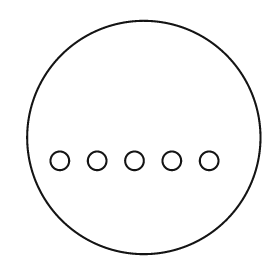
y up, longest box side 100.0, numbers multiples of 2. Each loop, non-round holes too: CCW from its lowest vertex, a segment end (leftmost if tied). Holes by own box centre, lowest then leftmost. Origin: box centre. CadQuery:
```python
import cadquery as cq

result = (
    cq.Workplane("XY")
    .moveTo(0.0, 0.0)
    .circle(50.0)
    .moveTo(-36.0, -10.0)
    .circle(4.0)
    .moveTo(-20.0, -10.0)
    .circle(4.0)
    .moveTo(-4.0, -10.0)
    .circle(4.0)
    .moveTo(12.0, -10.0)
    .circle(4.0)
    .moveTo(28.0, -10.0)
    .circle(4.0)
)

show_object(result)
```